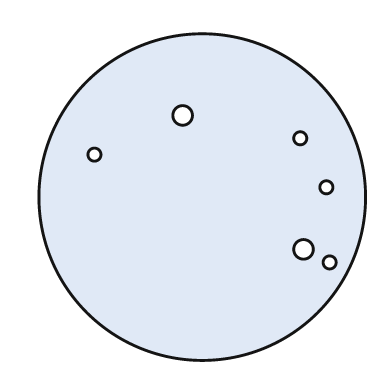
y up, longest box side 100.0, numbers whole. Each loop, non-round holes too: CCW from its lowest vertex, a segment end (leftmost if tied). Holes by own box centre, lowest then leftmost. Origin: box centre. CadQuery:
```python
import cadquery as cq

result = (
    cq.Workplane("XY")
    .moveTo(0.0, 0.0)
    .circle(50.0)
    .moveTo(39.0, -20.0)
    .circle(2.0)
    .moveTo(31.0, -16.0)
    .circle(3.0)
    .moveTo(38.0, 3.0)
    .circle(2.0)
    .moveTo(-33.0, 13.0)
    .circle(2.0)
    .moveTo(30.0, 18.0)
    .circle(2.0)
    .moveTo(-6.0, 25.0)
    .circle(3.0)
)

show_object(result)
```